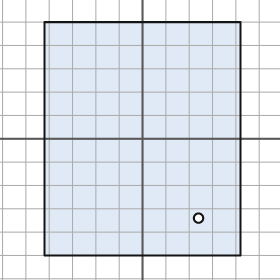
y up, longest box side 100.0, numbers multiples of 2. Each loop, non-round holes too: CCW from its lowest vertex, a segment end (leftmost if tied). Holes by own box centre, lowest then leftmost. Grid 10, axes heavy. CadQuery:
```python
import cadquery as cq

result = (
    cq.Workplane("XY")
    .moveTo(-42.0, -50.0)
    .lineTo(42.0, -50.0)
    .lineTo(42.0, 50.0)
    .lineTo(-42.0, 50.0)
    .close()
    .moveTo(24.0, -34.0)
    .circle(2.0)
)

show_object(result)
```